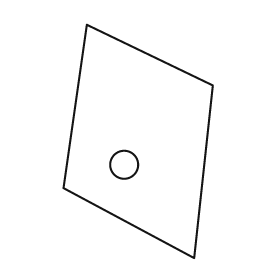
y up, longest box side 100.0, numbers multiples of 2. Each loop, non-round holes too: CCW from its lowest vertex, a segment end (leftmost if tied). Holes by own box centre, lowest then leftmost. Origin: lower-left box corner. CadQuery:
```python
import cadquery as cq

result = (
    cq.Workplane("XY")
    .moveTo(56.0, 0.0)
    .lineTo(64.0, 74.0)
    .lineTo(10.0, 100.0)
    .lineTo(0.0, 30.0)
    .close()
    .moveTo(26.0, 40.0)
    .circle(6.0)
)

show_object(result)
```